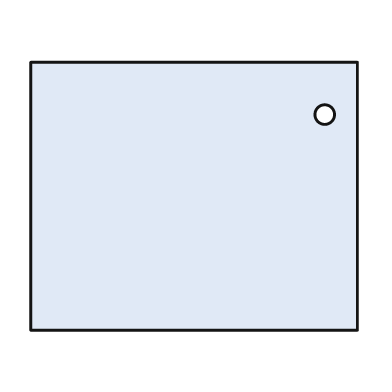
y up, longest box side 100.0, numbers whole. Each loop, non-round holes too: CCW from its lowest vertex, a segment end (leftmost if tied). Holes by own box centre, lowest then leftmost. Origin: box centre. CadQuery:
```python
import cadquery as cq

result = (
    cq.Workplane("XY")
    .moveTo(-50.0, -41.0)
    .lineTo(50.0, -41.0)
    .lineTo(50.0, 41.0)
    .lineTo(-50.0, 41.0)
    .close()
    .moveTo(40.0, 25.0)
    .circle(3.0)
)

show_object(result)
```